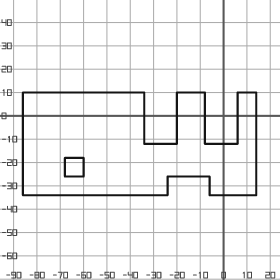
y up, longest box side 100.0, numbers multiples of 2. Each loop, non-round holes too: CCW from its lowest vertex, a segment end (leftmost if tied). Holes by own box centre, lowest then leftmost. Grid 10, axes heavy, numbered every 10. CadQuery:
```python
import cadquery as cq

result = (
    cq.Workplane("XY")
    .moveTo(-86.0, -34.0)
    .lineTo(-24.0, -34.0)
    .lineTo(-24.0, -26.0)
    .lineTo(-6.0, -26.0)
    .lineTo(-6.0, -34.0)
    .lineTo(14.0, -34.0)
    .lineTo(14.0, 10.0)
    .lineTo(6.0, 10.0)
    .lineTo(6.0, -12.0)
    .lineTo(-8.0, -12.0)
    .lineTo(-8.0, 10.0)
    .lineTo(-20.0, 10.0)
    .lineTo(-20.0, -12.0)
    .lineTo(-34.0, -12.0)
    .lineTo(-34.0, 10.0)
    .lineTo(-86.0, 10.0)
    .close()
    .moveTo(-68.0, -26.0)
    .lineTo(-60.0, -26.0)
    .lineTo(-60.0, -18.0)
    .lineTo(-68.0, -18.0)
    .close()
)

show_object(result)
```